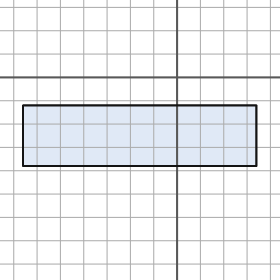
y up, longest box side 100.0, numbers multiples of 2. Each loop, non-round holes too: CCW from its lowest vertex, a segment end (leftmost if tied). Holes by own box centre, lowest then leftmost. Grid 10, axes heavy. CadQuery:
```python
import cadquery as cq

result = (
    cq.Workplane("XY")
    .moveTo(-66.0, -38.0)
    .lineTo(34.0, -38.0)
    .lineTo(34.0, -12.0)
    .lineTo(-66.0, -12.0)
    .close()
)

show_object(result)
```